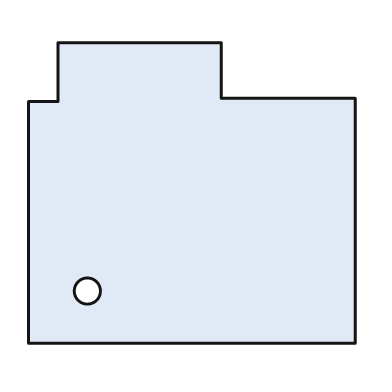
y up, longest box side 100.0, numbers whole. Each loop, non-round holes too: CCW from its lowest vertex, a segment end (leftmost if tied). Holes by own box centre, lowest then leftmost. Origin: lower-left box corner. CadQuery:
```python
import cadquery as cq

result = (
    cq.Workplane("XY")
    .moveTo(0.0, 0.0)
    .lineTo(100.0, 0.0)
    .lineTo(100.0, 75.0)
    .lineTo(59.0, 75.0)
    .lineTo(59.0, 92.0)
    .lineTo(9.0, 92.0)
    .lineTo(9.0, 74.0)
    .lineTo(0.0, 74.0)
    .close()
    .moveTo(18.0, 16.0)
    .circle(4.0)
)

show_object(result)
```